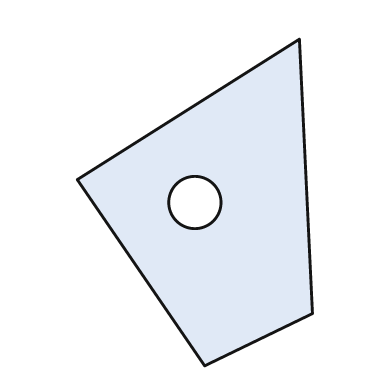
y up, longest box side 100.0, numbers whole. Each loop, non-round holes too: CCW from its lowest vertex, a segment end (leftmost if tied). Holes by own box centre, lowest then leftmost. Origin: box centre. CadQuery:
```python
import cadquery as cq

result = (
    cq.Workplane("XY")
    .moveTo(3.0, -50.0)
    .lineTo(36.0, -34.0)
    .lineTo(32.0, 50.0)
    .lineTo(-36.0, 7.0)
    .close()
    .moveTo(0.0, 0.0)
    .circle(8.0)
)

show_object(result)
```